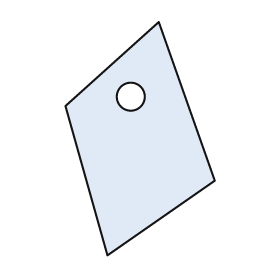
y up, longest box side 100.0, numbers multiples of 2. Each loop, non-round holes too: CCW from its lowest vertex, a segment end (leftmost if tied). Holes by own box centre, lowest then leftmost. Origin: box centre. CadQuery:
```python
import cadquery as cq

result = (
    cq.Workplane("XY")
    .moveTo(-14.0, -50.0)
    .lineTo(32.0, -18.0)
    .lineTo(8.0, 50.0)
    .lineTo(-32.0, 14.0)
    .close()
    .moveTo(-4.0, 18.0)
    .circle(6.0)
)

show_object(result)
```